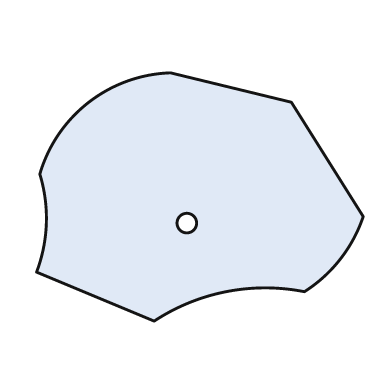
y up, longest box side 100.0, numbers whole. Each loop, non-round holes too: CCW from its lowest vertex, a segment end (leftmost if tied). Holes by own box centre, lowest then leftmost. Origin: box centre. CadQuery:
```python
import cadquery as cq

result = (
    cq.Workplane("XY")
    .moveTo(-14.0, -38.0)
    .threePointArc((8.0, -29.0), (32.0, -29.0))
    .threePointArc((43.0, -19.0), (50.0, -6.0))
    .lineTo(28.0, 29.0)
    .lineTo(-9.0, 38.0)
    .threePointArc((-34.0, 29.0), (-49.0, 7.0))
    .threePointArc((-47.0, -8.0), (-50.0, -23.0))
    .close()
    .moveTo(-4.0, -8.0)
    .circle(3.0)
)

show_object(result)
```